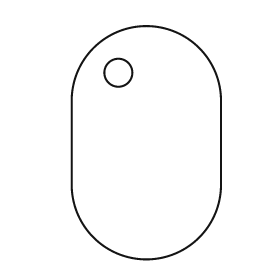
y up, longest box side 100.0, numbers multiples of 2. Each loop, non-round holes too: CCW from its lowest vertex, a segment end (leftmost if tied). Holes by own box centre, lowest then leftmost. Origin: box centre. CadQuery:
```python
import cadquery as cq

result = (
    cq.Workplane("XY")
    .moveTo(-32.0, -18.0)
    .threePointArc((0.0, -50.0), (32.0, -18.0))
    .lineTo(32.0, 18.0)
    .threePointArc((0.0, 50.0), (-32.0, 18.0))
    .close()
    .moveTo(-12.0, 30.0)
    .circle(6.0)
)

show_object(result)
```